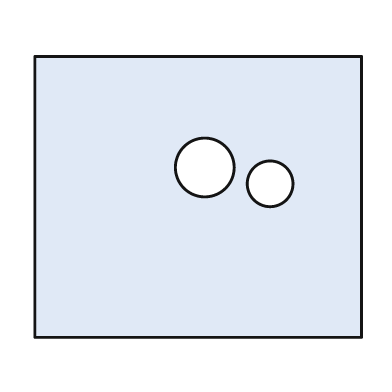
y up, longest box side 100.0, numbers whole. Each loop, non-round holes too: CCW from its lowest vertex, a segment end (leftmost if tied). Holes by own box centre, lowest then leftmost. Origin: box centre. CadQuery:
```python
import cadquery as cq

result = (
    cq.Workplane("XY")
    .moveTo(-50.0, -43.0)
    .lineTo(50.0, -43.0)
    .lineTo(50.0, 43.0)
    .lineTo(-50.0, 43.0)
    .close()
    .moveTo(22.0, 4.0)
    .circle(7.0)
    .moveTo(2.0, 9.0)
    .circle(9.0)
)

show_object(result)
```